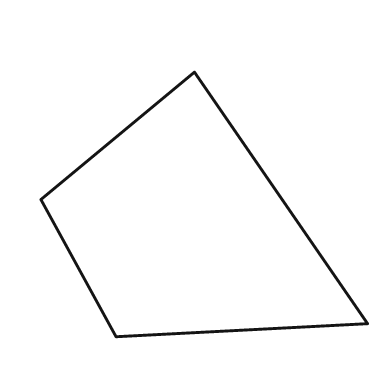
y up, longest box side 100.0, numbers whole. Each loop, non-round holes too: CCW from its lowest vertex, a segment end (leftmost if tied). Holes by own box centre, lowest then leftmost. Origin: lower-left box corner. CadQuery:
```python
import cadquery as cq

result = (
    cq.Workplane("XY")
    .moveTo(23.0, 0.0)
    .lineTo(100.0, 4.0)
    .lineTo(47.0, 81.0)
    .lineTo(0.0, 42.0)
    .close()
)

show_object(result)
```